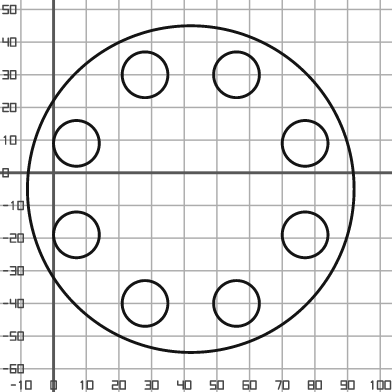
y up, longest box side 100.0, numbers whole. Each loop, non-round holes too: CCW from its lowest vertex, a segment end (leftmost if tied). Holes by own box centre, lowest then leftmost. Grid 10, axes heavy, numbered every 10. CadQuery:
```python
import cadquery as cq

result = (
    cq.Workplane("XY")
    .moveTo(42.0, -5.0)
    .circle(50.0)
    .moveTo(28.0, -40.0)
    .circle(7.0)
    .moveTo(56.0, -40.0)
    .circle(7.0)
    .moveTo(7.0, -19.0)
    .circle(7.0)
    .moveTo(77.0, -19.0)
    .circle(7.0)
    .moveTo(7.0, 9.0)
    .circle(7.0)
    .moveTo(77.0, 9.0)
    .circle(7.0)
    .moveTo(28.0, 30.0)
    .circle(7.0)
    .moveTo(56.0, 30.0)
    .circle(7.0)
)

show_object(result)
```